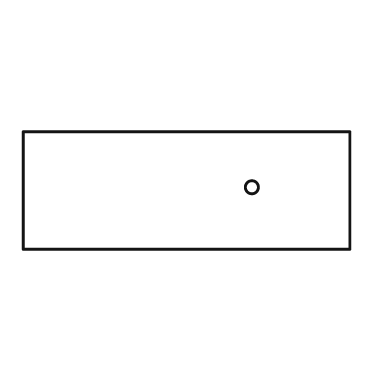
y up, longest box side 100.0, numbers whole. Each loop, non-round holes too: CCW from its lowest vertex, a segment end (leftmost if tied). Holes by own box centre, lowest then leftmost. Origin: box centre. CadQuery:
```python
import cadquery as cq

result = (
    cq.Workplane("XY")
    .moveTo(-50.0, -18.0)
    .lineTo(50.0, -18.0)
    .lineTo(50.0, 18.0)
    .lineTo(-50.0, 18.0)
    .close()
    .moveTo(20.0, 1.0)
    .circle(2.0)
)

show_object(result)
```